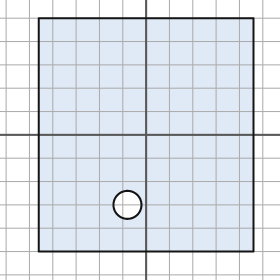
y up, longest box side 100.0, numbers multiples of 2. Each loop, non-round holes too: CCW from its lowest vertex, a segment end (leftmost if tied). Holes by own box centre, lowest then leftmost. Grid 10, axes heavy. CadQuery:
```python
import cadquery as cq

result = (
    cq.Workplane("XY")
    .moveTo(-46.0, -50.0)
    .lineTo(46.0, -50.0)
    .lineTo(46.0, 50.0)
    .lineTo(-46.0, 50.0)
    .close()
    .moveTo(-8.0, -30.0)
    .circle(6.0)
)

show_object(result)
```